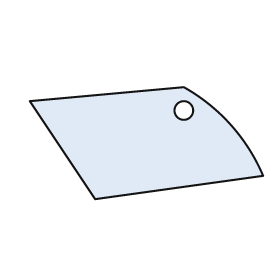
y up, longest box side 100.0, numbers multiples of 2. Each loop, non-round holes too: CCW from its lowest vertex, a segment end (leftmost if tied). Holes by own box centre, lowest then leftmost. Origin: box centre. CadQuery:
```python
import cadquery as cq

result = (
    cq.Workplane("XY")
    .moveTo(-22.0, -24.0)
    .lineTo(50.0, -14.0)
    .threePointArc((36.0, 8.0), (16.0, 24.0))
    .lineTo(-50.0, 18.0)
    .close()
    .moveTo(16.0, 14.0)
    .circle(4.0)
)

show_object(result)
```